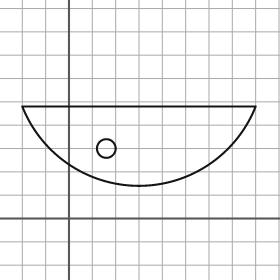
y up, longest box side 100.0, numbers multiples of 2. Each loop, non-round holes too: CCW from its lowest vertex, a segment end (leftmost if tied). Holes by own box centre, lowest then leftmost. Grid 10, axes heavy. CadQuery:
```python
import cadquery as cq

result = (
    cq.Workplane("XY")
    .moveTo(-20.0, 48.0)
    .threePointArc((30.0, 14.0), (80.0, 48.0))
    .close()
    .moveTo(16.0, 30.0)
    .circle(4.0)
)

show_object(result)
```